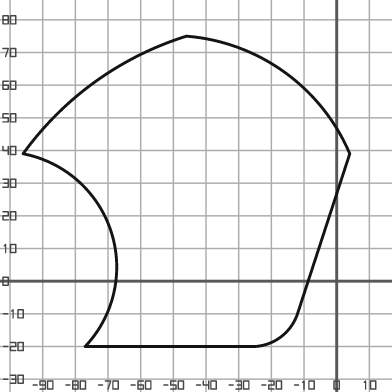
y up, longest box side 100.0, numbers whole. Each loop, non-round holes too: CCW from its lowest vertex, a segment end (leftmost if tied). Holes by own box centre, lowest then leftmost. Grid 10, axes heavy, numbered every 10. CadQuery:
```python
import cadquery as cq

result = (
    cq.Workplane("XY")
    .moveTo(-77.0, -20.0)
    .lineTo(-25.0, -20.0)
    .threePointArc((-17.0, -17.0), (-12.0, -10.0))
    .lineTo(4.0, 39.0)
    .threePointArc((-16.0, 64.0), (-46.0, 75.0))
    .threePointArc((-74.0, 61.0), (-96.0, 39.0))
    .threePointArc((-69.0, 15.0), (-77.0, -20.0))
    .close()
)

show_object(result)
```